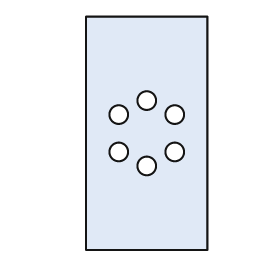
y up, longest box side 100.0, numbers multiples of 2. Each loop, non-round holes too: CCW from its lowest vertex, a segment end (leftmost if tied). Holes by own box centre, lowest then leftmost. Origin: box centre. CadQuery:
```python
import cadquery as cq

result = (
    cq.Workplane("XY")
    .moveTo(-26.0, -50.0)
    .lineTo(26.0, -50.0)
    .lineTo(26.0, 50.0)
    .lineTo(-26.0, 50.0)
    .close()
    .moveTo(0.0, -14.0)
    .circle(4.0)
    .moveTo(-12.0, -8.0)
    .circle(4.0)
    .moveTo(12.0, -8.0)
    .circle(4.0)
    .moveTo(-12.0, 8.0)
    .circle(4.0)
    .moveTo(12.0, 8.0)
    .circle(4.0)
    .moveTo(0.0, 14.0)
    .circle(4.0)
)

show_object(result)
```